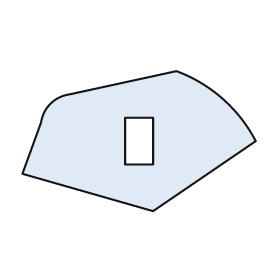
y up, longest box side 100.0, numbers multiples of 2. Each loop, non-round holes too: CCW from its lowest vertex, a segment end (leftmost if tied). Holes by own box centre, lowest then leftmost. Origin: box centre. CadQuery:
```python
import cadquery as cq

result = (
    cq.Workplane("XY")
    .moveTo(6.0, -30.0)
    .lineTo(50.0, 0.0)
    .threePointArc((36.0, 18.0), (16.0, 30.0))
    .lineTo(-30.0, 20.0)
    .threePointArc((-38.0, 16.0), (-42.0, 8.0))
    .lineTo(-50.0, -14.0)
    .close()
    .moveTo(-6.0, -10.0)
    .lineTo(6.0, -10.0)
    .lineTo(6.0, 10.0)
    .lineTo(-6.0, 10.0)
    .close()
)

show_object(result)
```